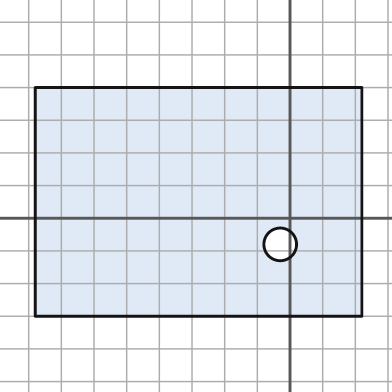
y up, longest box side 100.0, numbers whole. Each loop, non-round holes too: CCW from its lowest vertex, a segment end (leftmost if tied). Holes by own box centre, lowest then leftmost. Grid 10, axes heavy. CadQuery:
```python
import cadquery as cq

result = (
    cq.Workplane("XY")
    .moveTo(-78.0, -30.0)
    .lineTo(22.0, -30.0)
    .lineTo(22.0, 40.0)
    .lineTo(-78.0, 40.0)
    .close()
    .moveTo(-3.0, -8.0)
    .circle(5.0)
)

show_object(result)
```